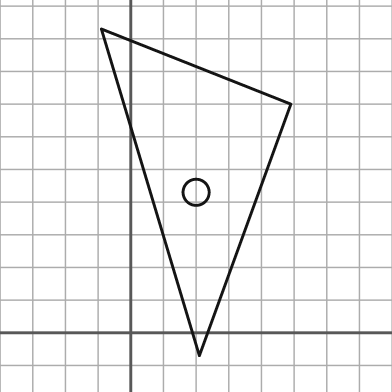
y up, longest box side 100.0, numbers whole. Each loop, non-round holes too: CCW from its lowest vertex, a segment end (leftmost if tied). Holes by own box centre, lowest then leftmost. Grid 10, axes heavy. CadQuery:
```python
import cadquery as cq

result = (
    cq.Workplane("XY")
    .moveTo(21.0, -7.0)
    .lineTo(49.0, 70.0)
    .lineTo(-9.0, 93.0)
    .close()
    .moveTo(20.0, 43.0)
    .circle(4.0)
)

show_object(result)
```